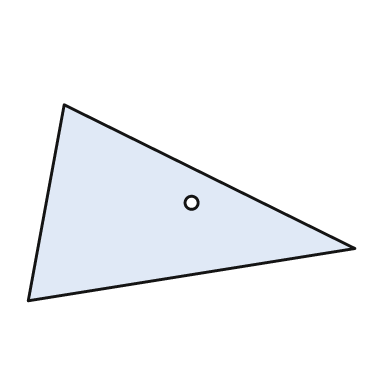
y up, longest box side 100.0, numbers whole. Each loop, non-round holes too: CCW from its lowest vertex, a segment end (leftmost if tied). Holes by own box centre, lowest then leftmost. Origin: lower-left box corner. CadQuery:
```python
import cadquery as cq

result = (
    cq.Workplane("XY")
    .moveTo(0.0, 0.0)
    .lineTo(100.0, 16.0)
    .lineTo(11.0, 60.0)
    .close()
    .moveTo(50.0, 30.0)
    .circle(2.0)
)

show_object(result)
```